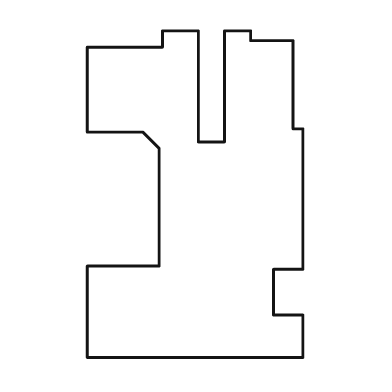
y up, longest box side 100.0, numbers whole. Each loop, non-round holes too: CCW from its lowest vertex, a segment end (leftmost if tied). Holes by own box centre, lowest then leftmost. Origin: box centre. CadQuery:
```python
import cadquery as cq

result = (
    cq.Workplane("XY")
    .moveTo(-33.0, -50.0)
    .lineTo(33.0, -50.0)
    .lineTo(33.0, -37.0)
    .lineTo(24.0, -37.0)
    .lineTo(24.0, -23.0)
    .lineTo(33.0, -23.0)
    .lineTo(33.0, 20.0)
    .lineTo(30.0, 20.0)
    .lineTo(30.0, 47.0)
    .lineTo(17.0, 47.0)
    .lineTo(17.0, 50.0)
    .lineTo(9.0, 50.0)
    .lineTo(9.0, 16.0)
    .lineTo(1.0, 16.0)
    .lineTo(1.0, 50.0)
    .lineTo(-10.0, 50.0)
    .lineTo(-10.0, 45.0)
    .lineTo(-33.0, 45.0)
    .lineTo(-33.0, 19.0)
    .lineTo(-16.0, 19.0)
    .lineTo(-11.0, 14.0)
    .lineTo(-11.0, -22.0)
    .lineTo(-33.0, -22.0)
    .close()
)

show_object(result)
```